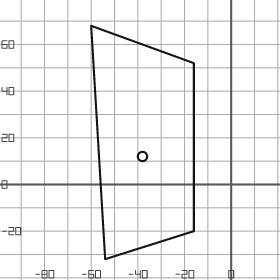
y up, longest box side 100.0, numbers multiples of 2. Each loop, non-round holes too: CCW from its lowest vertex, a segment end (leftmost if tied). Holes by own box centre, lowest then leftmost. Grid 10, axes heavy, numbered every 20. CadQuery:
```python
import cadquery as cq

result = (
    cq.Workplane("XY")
    .moveTo(-54.0, -32.0)
    .lineTo(-16.0, -20.0)
    .lineTo(-16.0, 52.0)
    .lineTo(-60.0, 68.0)
    .close()
    .moveTo(-38.0, 12.0)
    .circle(2.0)
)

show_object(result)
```